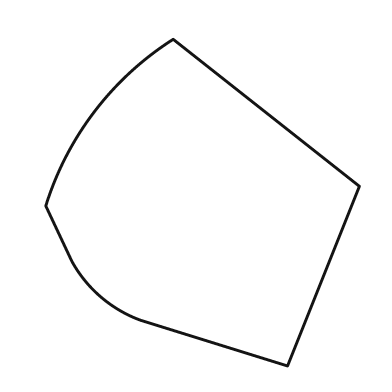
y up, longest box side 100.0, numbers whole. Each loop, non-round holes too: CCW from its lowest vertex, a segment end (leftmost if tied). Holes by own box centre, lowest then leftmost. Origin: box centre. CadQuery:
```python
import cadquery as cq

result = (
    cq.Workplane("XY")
    .moveTo(26.0, -50.0)
    .lineTo(48.0, 5.0)
    .lineTo(-9.0, 50.0)
    .threePointArc((-33.0, 28.0), (-48.0, -1.0))
    .lineTo(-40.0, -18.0)
    .threePointArc((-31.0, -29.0), (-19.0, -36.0))
    .close()
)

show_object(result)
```